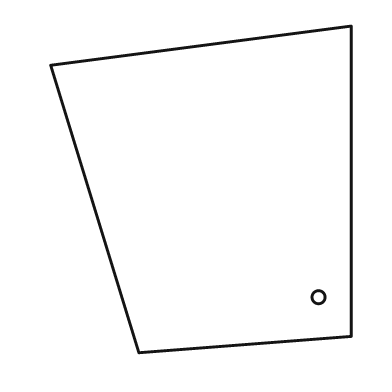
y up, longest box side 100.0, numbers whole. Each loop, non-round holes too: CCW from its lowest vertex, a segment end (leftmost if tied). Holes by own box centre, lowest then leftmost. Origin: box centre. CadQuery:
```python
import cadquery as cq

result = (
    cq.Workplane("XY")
    .moveTo(-19.0, -50.0)
    .lineTo(46.0, -45.0)
    .lineTo(46.0, 50.0)
    .lineTo(-46.0, 38.0)
    .close()
    .moveTo(36.0, -33.0)
    .circle(2.0)
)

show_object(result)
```